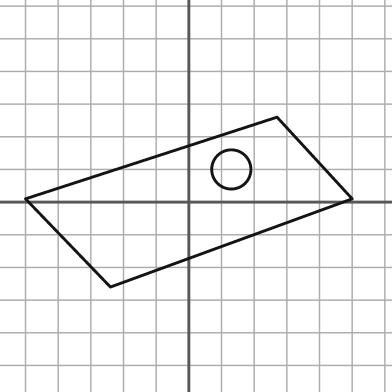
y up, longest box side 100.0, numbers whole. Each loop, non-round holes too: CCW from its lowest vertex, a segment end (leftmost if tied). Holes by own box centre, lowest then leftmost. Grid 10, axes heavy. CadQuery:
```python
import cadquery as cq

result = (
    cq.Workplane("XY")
    .moveTo(-24.0, -26.0)
    .lineTo(50.0, 1.0)
    .lineTo(27.0, 26.0)
    .lineTo(-50.0, 1.0)
    .close()
    .moveTo(13.0, 10.0)
    .circle(6.0)
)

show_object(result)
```